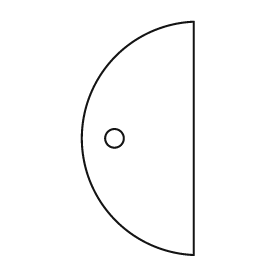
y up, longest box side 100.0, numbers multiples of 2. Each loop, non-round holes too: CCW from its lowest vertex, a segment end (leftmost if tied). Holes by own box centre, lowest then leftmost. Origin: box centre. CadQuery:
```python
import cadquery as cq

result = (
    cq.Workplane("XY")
    .moveTo(24.0, -50.0)
    .lineTo(24.0, 50.0)
    .threePointArc((-24.0, 0.0), (24.0, -50.0))
    .close()
    .moveTo(-10.0, 0.0)
    .circle(4.0)
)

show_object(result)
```